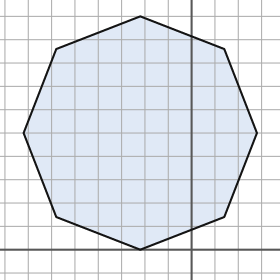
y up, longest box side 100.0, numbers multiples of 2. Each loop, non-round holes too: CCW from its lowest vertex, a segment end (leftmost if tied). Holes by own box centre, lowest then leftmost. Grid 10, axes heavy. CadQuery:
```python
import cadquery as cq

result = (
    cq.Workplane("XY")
    .moveTo(-22.0, 0.0)
    .lineTo(14.0, 14.0)
    .lineTo(28.0, 50.0)
    .lineTo(14.0, 86.0)
    .lineTo(-22.0, 100.0)
    .lineTo(-58.0, 86.0)
    .lineTo(-72.0, 50.0)
    .lineTo(-58.0, 14.0)
    .close()
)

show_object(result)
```